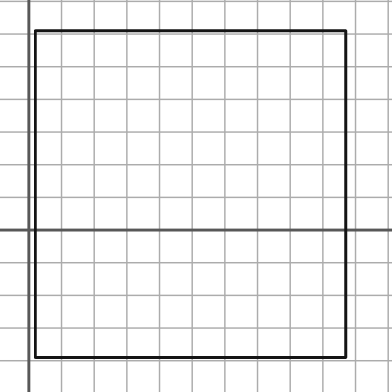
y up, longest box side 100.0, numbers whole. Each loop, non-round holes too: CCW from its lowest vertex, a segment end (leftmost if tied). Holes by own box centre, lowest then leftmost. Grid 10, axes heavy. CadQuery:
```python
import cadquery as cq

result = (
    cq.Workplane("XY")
    .moveTo(2.0, -39.0)
    .lineTo(97.0, -39.0)
    .lineTo(97.0, 61.0)
    .lineTo(2.0, 61.0)
    .close()
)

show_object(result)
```